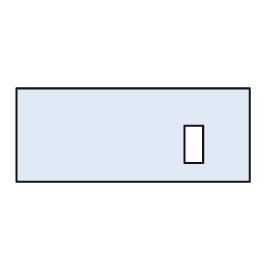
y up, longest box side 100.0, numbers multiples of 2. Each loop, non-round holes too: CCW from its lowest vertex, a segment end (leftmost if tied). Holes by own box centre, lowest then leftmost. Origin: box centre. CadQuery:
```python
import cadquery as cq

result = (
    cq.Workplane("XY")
    .moveTo(-50.0, -20.0)
    .lineTo(50.0, -20.0)
    .lineTo(50.0, 20.0)
    .lineTo(-50.0, 20.0)
    .close()
    .moveTo(22.0, -12.0)
    .lineTo(30.0, -12.0)
    .lineTo(30.0, 4.0)
    .lineTo(22.0, 4.0)
    .close()
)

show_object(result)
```